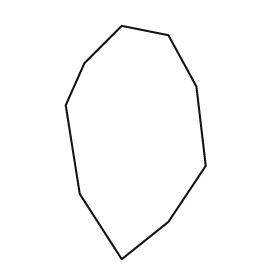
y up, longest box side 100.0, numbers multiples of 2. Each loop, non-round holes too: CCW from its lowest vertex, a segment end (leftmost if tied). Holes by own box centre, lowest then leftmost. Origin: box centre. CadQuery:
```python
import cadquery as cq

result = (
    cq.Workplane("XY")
    .moveTo(-6.0, -50.0)
    .lineTo(14.0, -34.0)
    .lineTo(30.0, -10.0)
    .lineTo(26.0, 24.0)
    .lineTo(14.0, 46.0)
    .lineTo(-6.0, 50.0)
    .lineTo(-22.0, 34.0)
    .lineTo(-30.0, 16.0)
    .lineTo(-24.0, -22.0)
    .close()
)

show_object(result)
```